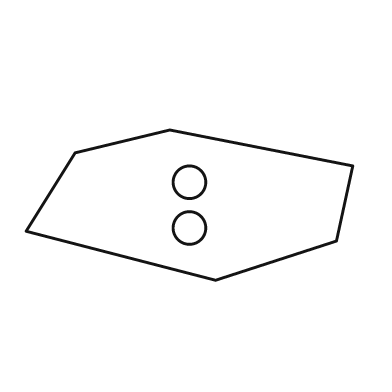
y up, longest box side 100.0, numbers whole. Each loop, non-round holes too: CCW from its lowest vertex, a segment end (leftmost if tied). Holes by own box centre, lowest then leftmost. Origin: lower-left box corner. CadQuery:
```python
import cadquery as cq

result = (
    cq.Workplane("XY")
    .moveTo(58.0, 0.0)
    .lineTo(95.0, 12.0)
    .lineTo(100.0, 35.0)
    .lineTo(44.0, 46.0)
    .lineTo(15.0, 39.0)
    .lineTo(0.0, 15.0)
    .close()
    .moveTo(50.0, 16.0)
    .circle(5.0)
    .moveTo(50.0, 30.0)
    .circle(5.0)
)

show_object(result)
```